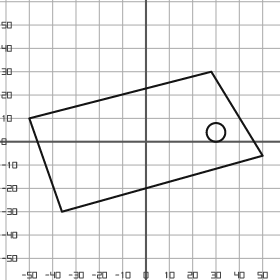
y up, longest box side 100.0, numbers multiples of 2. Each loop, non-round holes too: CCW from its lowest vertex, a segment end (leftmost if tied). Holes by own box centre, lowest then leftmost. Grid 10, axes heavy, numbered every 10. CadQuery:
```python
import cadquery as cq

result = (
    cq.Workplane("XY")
    .moveTo(-36.0, -30.0)
    .lineTo(50.0, -6.0)
    .lineTo(28.0, 30.0)
    .lineTo(-50.0, 10.0)
    .close()
    .moveTo(30.0, 4.0)
    .circle(4.0)
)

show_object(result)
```